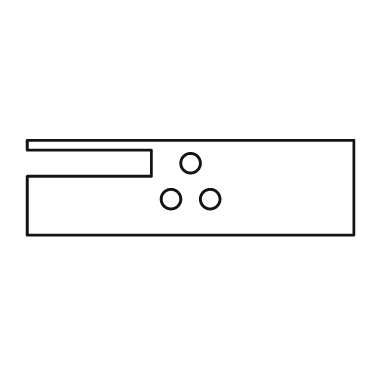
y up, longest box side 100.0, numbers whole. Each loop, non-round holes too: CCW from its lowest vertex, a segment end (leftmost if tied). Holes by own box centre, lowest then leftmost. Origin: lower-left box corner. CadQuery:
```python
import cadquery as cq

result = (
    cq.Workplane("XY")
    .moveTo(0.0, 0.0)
    .lineTo(100.0, 0.0)
    .lineTo(100.0, 29.0)
    .lineTo(0.0, 29.0)
    .lineTo(0.0, 26.0)
    .lineTo(38.0, 26.0)
    .lineTo(38.0, 18.0)
    .lineTo(0.0, 18.0)
    .close()
    .moveTo(44.0, 11.0)
    .circle(3.0)
    .moveTo(56.0, 11.0)
    .circle(3.0)
    .moveTo(50.0, 22.0)
    .circle(3.0)
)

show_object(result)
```